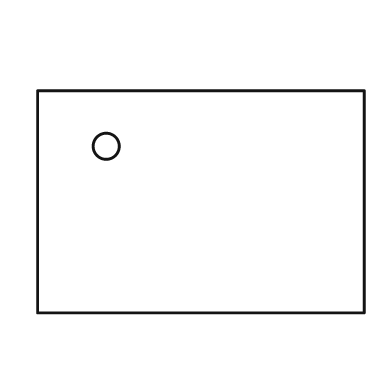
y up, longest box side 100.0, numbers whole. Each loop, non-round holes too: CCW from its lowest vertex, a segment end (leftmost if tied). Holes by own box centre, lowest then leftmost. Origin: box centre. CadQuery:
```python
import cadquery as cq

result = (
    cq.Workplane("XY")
    .moveTo(-50.0, -34.0)
    .lineTo(50.0, -34.0)
    .lineTo(50.0, 34.0)
    .lineTo(-50.0, 34.0)
    .close()
    .moveTo(-29.0, 17.0)
    .circle(4.0)
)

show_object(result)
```